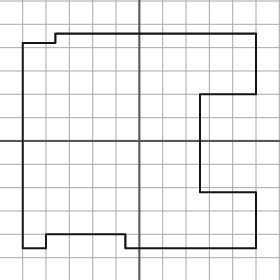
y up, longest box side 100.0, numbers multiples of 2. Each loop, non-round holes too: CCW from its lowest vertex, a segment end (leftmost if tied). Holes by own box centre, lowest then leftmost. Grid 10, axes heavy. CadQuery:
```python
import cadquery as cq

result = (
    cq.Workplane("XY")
    .moveTo(-50.0, -46.0)
    .lineTo(-40.0, -46.0)
    .lineTo(-40.0, -40.0)
    .lineTo(-6.0, -40.0)
    .lineTo(-6.0, -46.0)
    .lineTo(50.0, -46.0)
    .lineTo(50.0, -22.0)
    .lineTo(26.0, -22.0)
    .lineTo(26.0, 20.0)
    .lineTo(50.0, 20.0)
    .lineTo(50.0, 46.0)
    .lineTo(-36.0, 46.0)
    .lineTo(-36.0, 42.0)
    .lineTo(-50.0, 42.0)
    .close()
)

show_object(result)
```